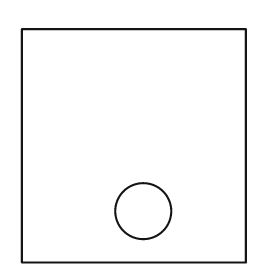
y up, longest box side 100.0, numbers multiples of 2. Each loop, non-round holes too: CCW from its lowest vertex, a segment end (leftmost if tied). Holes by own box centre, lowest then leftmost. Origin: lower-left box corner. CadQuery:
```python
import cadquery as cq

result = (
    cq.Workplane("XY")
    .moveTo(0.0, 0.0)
    .lineTo(96.0, 0.0)
    .lineTo(96.0, 100.0)
    .lineTo(0.0, 100.0)
    .close()
    .moveTo(52.0, 22.0)
    .circle(12.0)
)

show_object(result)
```